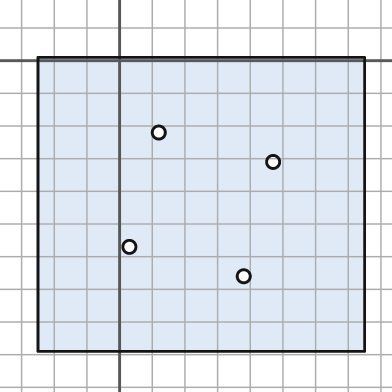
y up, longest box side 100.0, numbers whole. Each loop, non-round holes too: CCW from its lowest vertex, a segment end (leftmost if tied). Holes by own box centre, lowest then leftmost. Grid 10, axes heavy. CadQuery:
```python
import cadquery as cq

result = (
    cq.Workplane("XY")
    .moveTo(-25.0, -89.0)
    .lineTo(75.0, -89.0)
    .lineTo(75.0, 1.0)
    .lineTo(-25.0, 1.0)
    .close()
    .moveTo(38.0, -66.0)
    .circle(2.0)
    .moveTo(3.0, -57.0)
    .circle(2.0)
    .moveTo(47.0, -31.0)
    .circle(2.0)
    .moveTo(12.0, -22.0)
    .circle(2.0)
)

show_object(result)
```